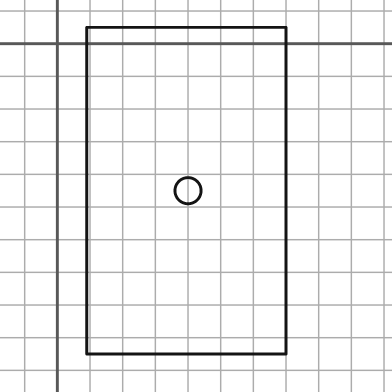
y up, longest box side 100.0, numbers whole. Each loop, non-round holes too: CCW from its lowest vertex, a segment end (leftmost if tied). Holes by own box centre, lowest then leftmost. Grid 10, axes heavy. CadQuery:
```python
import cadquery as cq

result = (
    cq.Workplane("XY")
    .moveTo(9.0, -95.0)
    .lineTo(70.0, -95.0)
    .lineTo(70.0, 5.0)
    .lineTo(9.0, 5.0)
    .close()
    .moveTo(40.0, -45.0)
    .circle(4.0)
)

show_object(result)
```